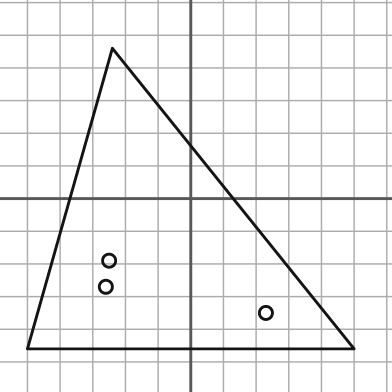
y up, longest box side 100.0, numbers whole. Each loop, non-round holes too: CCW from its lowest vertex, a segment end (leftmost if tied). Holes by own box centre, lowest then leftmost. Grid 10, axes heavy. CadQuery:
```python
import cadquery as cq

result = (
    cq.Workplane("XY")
    .moveTo(-50.0, -46.0)
    .lineTo(50.0, -46.0)
    .lineTo(-24.0, 46.0)
    .close()
    .moveTo(23.0, -35.0)
    .circle(2.0)
    .moveTo(-26.0, -27.0)
    .circle(2.0)
    .moveTo(-25.0, -19.0)
    .circle(2.0)
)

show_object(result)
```